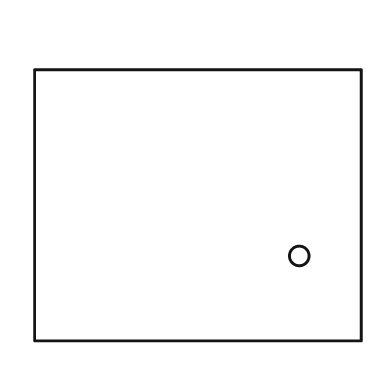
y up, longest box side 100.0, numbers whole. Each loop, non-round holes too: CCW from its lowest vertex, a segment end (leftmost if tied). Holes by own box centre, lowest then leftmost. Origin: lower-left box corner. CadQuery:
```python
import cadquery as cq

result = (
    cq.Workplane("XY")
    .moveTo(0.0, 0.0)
    .lineTo(100.0, 0.0)
    .lineTo(100.0, 83.0)
    .lineTo(0.0, 83.0)
    .close()
    .moveTo(81.0, 26.0)
    .circle(3.0)
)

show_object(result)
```